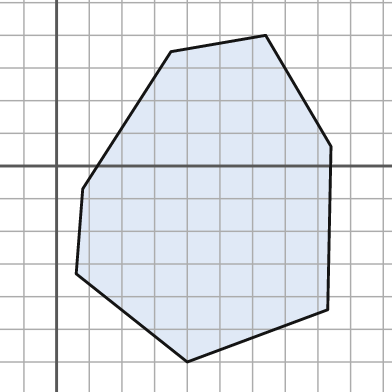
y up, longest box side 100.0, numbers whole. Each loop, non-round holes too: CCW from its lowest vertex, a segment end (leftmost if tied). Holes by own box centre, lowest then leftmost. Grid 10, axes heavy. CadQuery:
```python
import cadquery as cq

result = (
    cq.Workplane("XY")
    .moveTo(40.0, -60.0)
    .lineTo(83.0, -44.0)
    .lineTo(84.0, 6.0)
    .lineTo(64.0, 40.0)
    .lineTo(35.0, 35.0)
    .lineTo(8.0, -7.0)
    .lineTo(6.0, -33.0)
    .close()
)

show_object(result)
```